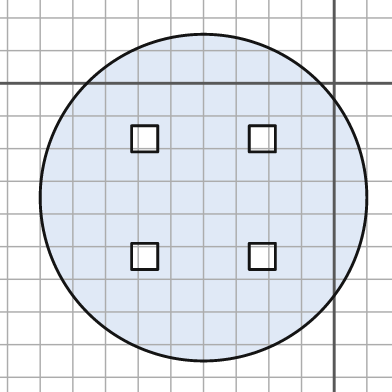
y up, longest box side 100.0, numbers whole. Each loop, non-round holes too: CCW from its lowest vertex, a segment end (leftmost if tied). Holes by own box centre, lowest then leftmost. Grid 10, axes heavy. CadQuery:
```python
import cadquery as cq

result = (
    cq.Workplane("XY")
    .moveTo(-40.0, -35.0)
    .circle(50.0)
    .moveTo(-62.0, -57.0)
    .lineTo(-54.0, -57.0)
    .lineTo(-54.0, -49.0)
    .lineTo(-62.0, -49.0)
    .close()
    .moveTo(-26.0, -57.0)
    .lineTo(-18.0, -57.0)
    .lineTo(-18.0, -49.0)
    .lineTo(-26.0, -49.0)
    .close()
    .moveTo(-62.0, -21.0)
    .lineTo(-54.0, -21.0)
    .lineTo(-54.0, -13.0)
    .lineTo(-62.0, -13.0)
    .close()
    .moveTo(-26.0, -21.0)
    .lineTo(-18.0, -21.0)
    .lineTo(-18.0, -13.0)
    .lineTo(-26.0, -13.0)
    .close()
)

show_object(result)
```